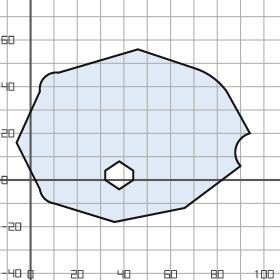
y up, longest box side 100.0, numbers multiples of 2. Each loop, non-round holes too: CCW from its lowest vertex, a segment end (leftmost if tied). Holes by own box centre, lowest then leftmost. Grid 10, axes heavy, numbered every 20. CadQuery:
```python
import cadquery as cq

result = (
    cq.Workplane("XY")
    .moveTo(36.0, -18.0)
    .lineTo(66.0, -12.0)
    .lineTo(90.0, 6.0)
    .threePointArc((88.0, 14.0), (94.0, 20.0))
    .lineTo(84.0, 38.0)
    .threePointArc((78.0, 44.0), (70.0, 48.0))
    .lineTo(46.0, 56.0)
    .lineTo(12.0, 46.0)
    .threePointArc((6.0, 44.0), (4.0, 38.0))
    .lineTo(-6.0, 16.0)
    .lineTo(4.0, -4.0)
    .threePointArc((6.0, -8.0), (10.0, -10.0))
    .close()
    .moveTo(38.0, -4.0)
    .lineTo(44.0, 0.0)
    .lineTo(44.0, 4.0)
    .lineTo(38.0, 8.0)
    .lineTo(32.0, 4.0)
    .lineTo(32.0, 0.0)
    .close()
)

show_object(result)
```